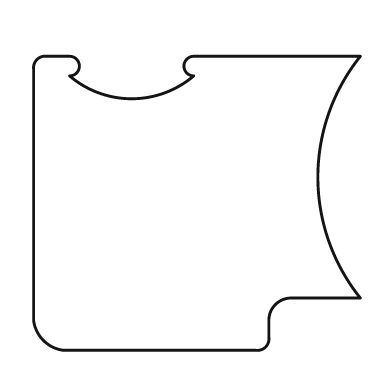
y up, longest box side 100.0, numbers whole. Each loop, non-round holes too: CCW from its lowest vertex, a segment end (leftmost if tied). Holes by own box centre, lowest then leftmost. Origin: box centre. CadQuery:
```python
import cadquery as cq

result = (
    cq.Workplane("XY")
    .moveTo(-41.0, -45.0)
    .lineTo(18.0, -45.0)
    .threePointArc((21.0, -44.0), (22.0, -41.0))
    .lineTo(22.0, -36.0)
    .threePointArc((24.0, -31.0), (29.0, -29.0))
    .lineTo(50.0, -29.0)
    .threePointArc((37.0, 8.0), (50.0, 45.0))
    .lineTo(-1.0, 45.0)
    .threePointArc((-4.0, 42.0), (-1.0, 39.0))
    .threePointArc((-20.0, 32.0), (-39.0, 39.0))
    .threePointArc((-36.0, 42.0), (-39.0, 45.0))
    .lineTo(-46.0, 45.0)
    .threePointArc((-49.0, 44.0), (-50.0, 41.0))
    .lineTo(-50.0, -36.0)
    .threePointArc((-47.0, -42.0), (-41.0, -45.0))
    .close()
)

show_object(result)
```